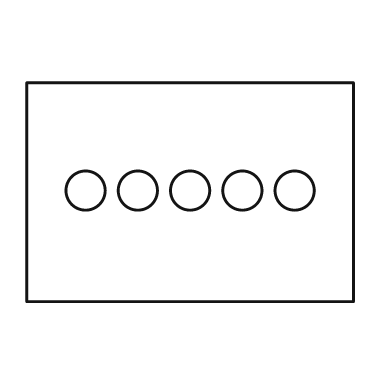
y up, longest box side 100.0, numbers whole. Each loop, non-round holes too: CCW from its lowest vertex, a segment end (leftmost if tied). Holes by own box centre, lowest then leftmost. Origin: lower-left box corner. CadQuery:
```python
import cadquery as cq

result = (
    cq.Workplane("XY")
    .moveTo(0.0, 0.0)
    .lineTo(100.0, 0.0)
    .lineTo(100.0, 67.0)
    .lineTo(0.0, 67.0)
    .close()
    .moveTo(18.0, 34.0)
    .circle(6.0)
    .moveTo(34.0, 34.0)
    .circle(6.0)
    .moveTo(50.0, 34.0)
    .circle(6.0)
    .moveTo(66.0, 34.0)
    .circle(6.0)
    .moveTo(82.0, 34.0)
    .circle(6.0)
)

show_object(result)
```